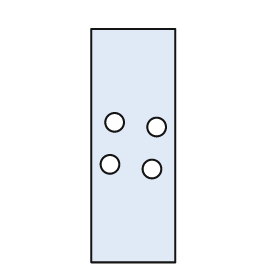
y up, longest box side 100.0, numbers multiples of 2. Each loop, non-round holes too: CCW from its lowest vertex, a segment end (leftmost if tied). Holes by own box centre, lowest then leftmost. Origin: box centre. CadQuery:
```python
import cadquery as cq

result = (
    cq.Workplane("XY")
    .moveTo(-18.0, -50.0)
    .lineTo(18.0, -50.0)
    .lineTo(18.0, 50.0)
    .lineTo(-18.0, 50.0)
    .close()
    .moveTo(8.0, -10.0)
    .circle(4.0)
    .moveTo(-10.0, -8.0)
    .circle(4.0)
    .moveTo(10.0, 8.0)
    .circle(4.0)
    .moveTo(-8.0, 10.0)
    .circle(4.0)
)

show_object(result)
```